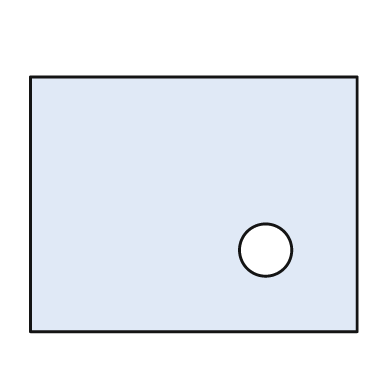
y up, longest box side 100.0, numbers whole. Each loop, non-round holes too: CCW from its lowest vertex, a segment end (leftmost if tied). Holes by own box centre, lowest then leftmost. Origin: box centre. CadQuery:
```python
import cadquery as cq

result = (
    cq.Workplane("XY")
    .moveTo(-50.0, -39.0)
    .lineTo(50.0, -39.0)
    .lineTo(50.0, 39.0)
    .lineTo(-50.0, 39.0)
    .close()
    .moveTo(22.0, -14.0)
    .circle(8.0)
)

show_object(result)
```